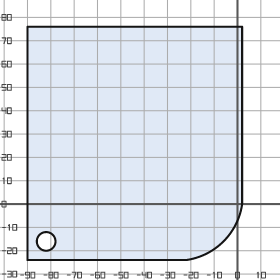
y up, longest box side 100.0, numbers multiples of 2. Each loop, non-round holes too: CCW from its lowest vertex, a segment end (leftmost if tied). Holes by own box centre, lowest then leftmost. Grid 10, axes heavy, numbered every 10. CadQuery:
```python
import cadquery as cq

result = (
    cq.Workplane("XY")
    .moveTo(-90.0, -24.0)
    .lineTo(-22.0, -24.0)
    .threePointArc((-6.0, -16.0), (2.0, 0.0))
    .lineTo(2.0, 76.0)
    .lineTo(-90.0, 76.0)
    .close()
    .moveTo(-82.0, -16.0)
    .circle(4.0)
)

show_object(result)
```